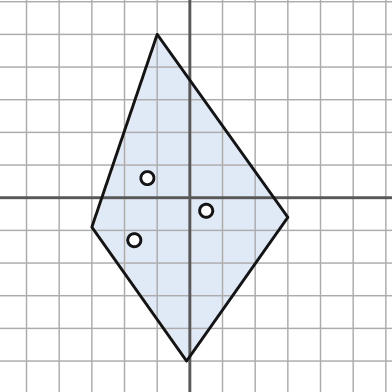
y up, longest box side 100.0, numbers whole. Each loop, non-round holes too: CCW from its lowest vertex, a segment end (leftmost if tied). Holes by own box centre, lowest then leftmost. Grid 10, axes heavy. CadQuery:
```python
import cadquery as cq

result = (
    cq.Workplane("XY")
    .moveTo(-1.0, -50.0)
    .lineTo(30.0, -6.0)
    .lineTo(-10.0, 50.0)
    .lineTo(-30.0, -9.0)
    .close()
    .moveTo(-17.0, -13.0)
    .circle(2.0)
    .moveTo(5.0, -4.0)
    .circle(2.0)
    .moveTo(-13.0, 6.0)
    .circle(2.0)
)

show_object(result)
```